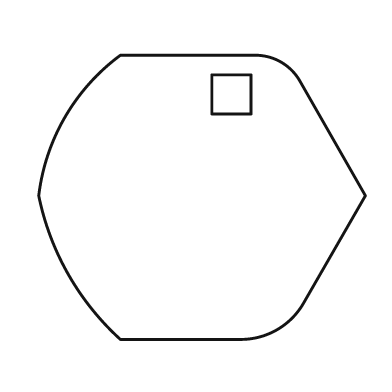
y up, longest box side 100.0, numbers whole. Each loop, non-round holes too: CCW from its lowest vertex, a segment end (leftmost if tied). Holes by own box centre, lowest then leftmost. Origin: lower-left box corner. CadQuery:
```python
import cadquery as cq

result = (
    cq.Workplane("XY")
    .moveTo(25.0, 0.0)
    .lineTo(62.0, 0.0)
    .threePointArc((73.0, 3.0), (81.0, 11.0))
    .lineTo(100.0, 44.0)
    .lineTo(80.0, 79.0)
    .threePointArc((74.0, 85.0), (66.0, 87.0))
    .lineTo(25.0, 87.0)
    .threePointArc((8.0, 68.0), (0.0, 44.0))
    .threePointArc((9.0, 20.0), (25.0, 0.0))
    .close()
    .moveTo(53.0, 69.0)
    .lineTo(65.0, 69.0)
    .lineTo(65.0, 81.0)
    .lineTo(53.0, 81.0)
    .close()
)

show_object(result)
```